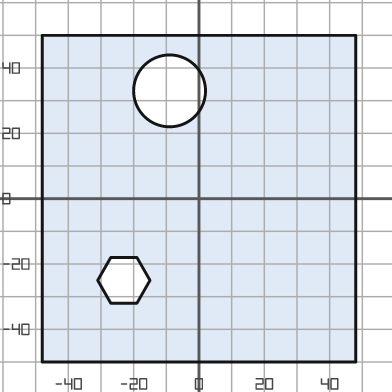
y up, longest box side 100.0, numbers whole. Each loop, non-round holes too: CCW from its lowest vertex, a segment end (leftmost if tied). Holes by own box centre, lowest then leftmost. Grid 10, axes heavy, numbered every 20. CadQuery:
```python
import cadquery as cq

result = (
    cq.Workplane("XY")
    .moveTo(-48.0, -50.0)
    .lineTo(48.0, -50.0)
    .lineTo(48.0, 50.0)
    .lineTo(-48.0, 50.0)
    .close()
    .moveTo(-27.0, -32.0)
    .lineTo(-19.0, -32.0)
    .lineTo(-15.0, -25.0)
    .lineTo(-19.0, -18.0)
    .lineTo(-27.0, -18.0)
    .lineTo(-31.0, -25.0)
    .close()
    .moveTo(-9.0, 33.0)
    .circle(11.0)
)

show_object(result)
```